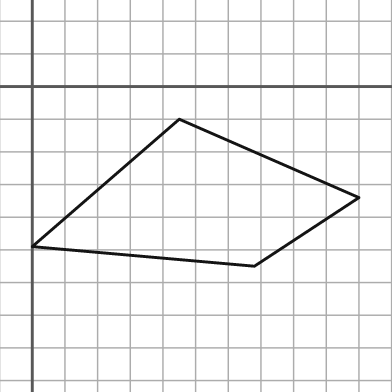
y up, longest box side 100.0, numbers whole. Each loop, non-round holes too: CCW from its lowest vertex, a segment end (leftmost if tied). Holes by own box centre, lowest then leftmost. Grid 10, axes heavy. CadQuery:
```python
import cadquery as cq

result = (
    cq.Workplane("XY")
    .moveTo(68.0, -55.0)
    .lineTo(100.0, -34.0)
    .lineTo(45.0, -10.0)
    .lineTo(0.0, -49.0)
    .close()
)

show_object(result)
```